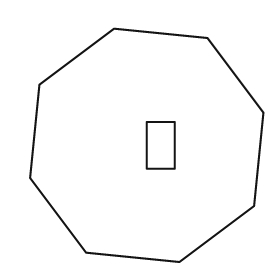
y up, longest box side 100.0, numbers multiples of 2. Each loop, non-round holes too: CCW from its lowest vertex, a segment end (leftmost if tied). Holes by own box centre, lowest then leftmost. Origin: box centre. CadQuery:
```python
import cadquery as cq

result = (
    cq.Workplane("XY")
    .moveTo(14.0, -50.0)
    .lineTo(46.0, -26.0)
    .lineTo(50.0, 14.0)
    .lineTo(26.0, 46.0)
    .lineTo(-14.0, 50.0)
    .lineTo(-46.0, 26.0)
    .lineTo(-50.0, -14.0)
    .lineTo(-26.0, -46.0)
    .close()
    .moveTo(0.0, -10.0)
    .lineTo(12.0, -10.0)
    .lineTo(12.0, 10.0)
    .lineTo(0.0, 10.0)
    .close()
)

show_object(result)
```